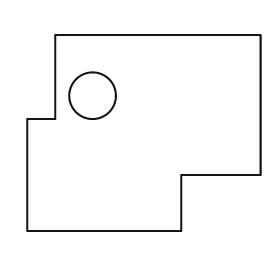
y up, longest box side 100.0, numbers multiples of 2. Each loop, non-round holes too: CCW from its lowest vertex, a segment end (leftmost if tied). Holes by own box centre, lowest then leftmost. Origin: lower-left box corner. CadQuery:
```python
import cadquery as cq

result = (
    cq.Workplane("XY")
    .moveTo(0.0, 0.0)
    .lineTo(66.0, 0.0)
    .lineTo(66.0, 24.0)
    .lineTo(100.0, 24.0)
    .lineTo(100.0, 84.0)
    .lineTo(12.0, 84.0)
    .lineTo(12.0, 48.0)
    .lineTo(0.0, 48.0)
    .close()
    .moveTo(28.0, 58.0)
    .circle(10.0)
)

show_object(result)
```